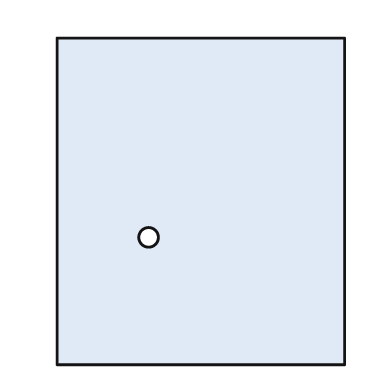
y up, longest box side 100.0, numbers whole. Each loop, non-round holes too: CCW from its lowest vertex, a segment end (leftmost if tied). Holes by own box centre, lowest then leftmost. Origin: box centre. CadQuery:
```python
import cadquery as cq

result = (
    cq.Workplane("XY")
    .moveTo(-44.0, -50.0)
    .lineTo(44.0, -50.0)
    .lineTo(44.0, 50.0)
    .lineTo(-44.0, 50.0)
    .close()
    .moveTo(-16.0, -11.0)
    .circle(3.0)
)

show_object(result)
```